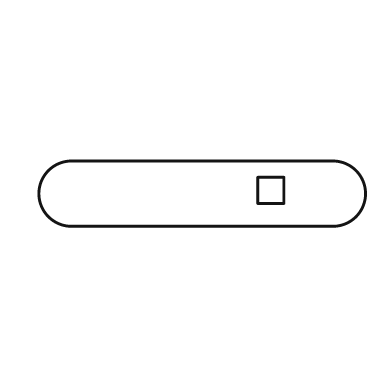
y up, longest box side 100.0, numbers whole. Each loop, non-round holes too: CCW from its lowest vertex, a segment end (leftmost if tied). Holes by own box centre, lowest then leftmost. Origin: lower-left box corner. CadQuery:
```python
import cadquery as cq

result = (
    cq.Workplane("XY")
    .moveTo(10.0, 0.0)
    .lineTo(90.0, 0.0)
    .threePointArc((100.0, 10.0), (90.0, 20.0))
    .lineTo(10.0, 20.0)
    .threePointArc((0.0, 10.0), (10.0, 0.0))
    .close()
    .moveTo(67.0, 7.0)
    .lineTo(75.0, 7.0)
    .lineTo(75.0, 15.0)
    .lineTo(67.0, 15.0)
    .close()
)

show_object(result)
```